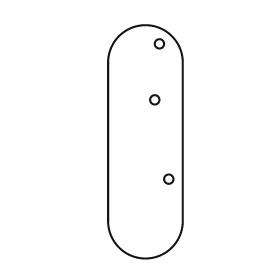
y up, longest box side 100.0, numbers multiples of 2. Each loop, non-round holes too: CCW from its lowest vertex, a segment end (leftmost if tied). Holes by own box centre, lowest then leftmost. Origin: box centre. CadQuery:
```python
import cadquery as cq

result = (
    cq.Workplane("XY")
    .moveTo(-16.0, -34.0)
    .threePointArc((0.0, -50.0), (16.0, -34.0))
    .lineTo(16.0, 34.0)
    .threePointArc((0.0, 50.0), (-16.0, 34.0))
    .close()
    .moveTo(10.0, -16.0)
    .circle(2.0)
    .moveTo(4.0, 18.0)
    .circle(2.0)
    .moveTo(6.0, 42.0)
    .circle(2.0)
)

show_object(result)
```